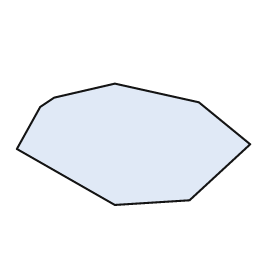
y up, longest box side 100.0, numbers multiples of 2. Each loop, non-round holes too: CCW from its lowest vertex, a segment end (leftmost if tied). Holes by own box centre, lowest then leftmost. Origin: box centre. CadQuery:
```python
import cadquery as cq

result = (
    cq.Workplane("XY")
    .moveTo(-8.0, -26.0)
    .lineTo(24.0, -24.0)
    .lineTo(50.0, 0.0)
    .lineTo(28.0, 18.0)
    .lineTo(-8.0, 26.0)
    .lineTo(-34.0, 20.0)
    .lineTo(-40.0, 16.0)
    .lineTo(-50.0, -2.0)
    .close()
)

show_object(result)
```